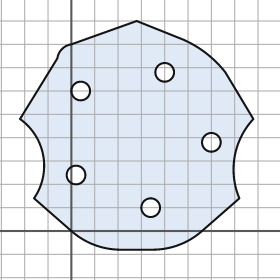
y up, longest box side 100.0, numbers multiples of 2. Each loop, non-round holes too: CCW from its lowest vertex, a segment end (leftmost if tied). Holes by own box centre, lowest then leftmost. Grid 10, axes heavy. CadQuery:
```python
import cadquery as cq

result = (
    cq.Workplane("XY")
    .moveTo(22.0, -8.0)
    .lineTo(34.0, -8.0)
    .threePointArc((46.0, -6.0), (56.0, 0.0))
    .lineTo(72.0, 14.0)
    .threePointArc((70.0, 32.0), (78.0, 48.0))
    .lineTo(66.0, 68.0)
    .threePointArc((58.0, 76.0), (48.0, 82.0))
    .lineTo(28.0, 90.0)
    .lineTo(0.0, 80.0)
    .threePointArc((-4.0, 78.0), (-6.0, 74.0))
    .lineTo(-22.0, 48.0)
    .threePointArc((-12.0, 32.0), (-16.0, 14.0))
    .lineTo(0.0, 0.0)
    .threePointArc((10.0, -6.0), (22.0, -8.0))
    .close()
    .moveTo(34.0, 10.0)
    .circle(4.0)
    .moveTo(2.0, 24.0)
    .circle(4.0)
    .moveTo(60.0, 38.0)
    .circle(4.0)
    .moveTo(4.0, 60.0)
    .circle(4.0)
    .moveTo(40.0, 68.0)
    .circle(4.0)
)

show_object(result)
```